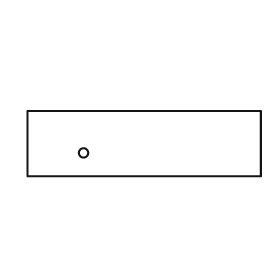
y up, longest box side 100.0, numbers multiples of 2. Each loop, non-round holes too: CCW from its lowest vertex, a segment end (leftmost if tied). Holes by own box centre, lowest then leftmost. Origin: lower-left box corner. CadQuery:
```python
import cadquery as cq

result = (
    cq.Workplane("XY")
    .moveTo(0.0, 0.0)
    .lineTo(100.0, 0.0)
    .lineTo(100.0, 28.0)
    .lineTo(0.0, 28.0)
    .close()
    .moveTo(24.0, 10.0)
    .circle(2.0)
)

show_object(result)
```